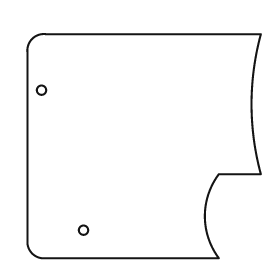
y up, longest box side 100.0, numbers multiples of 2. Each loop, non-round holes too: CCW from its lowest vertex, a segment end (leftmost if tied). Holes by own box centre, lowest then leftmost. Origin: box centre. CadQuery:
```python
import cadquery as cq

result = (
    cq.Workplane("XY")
    .moveTo(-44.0, -48.0)
    .lineTo(32.0, -48.0)
    .threePointArc((26.0, -30.0), (32.0, -12.0))
    .lineTo(50.0, -12.0)
    .threePointArc((46.0, 18.0), (50.0, 48.0))
    .lineTo(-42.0, 48.0)
    .threePointArc((-48.0, 46.0), (-50.0, 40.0))
    .lineTo(-50.0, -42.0)
    .threePointArc((-48.0, -46.0), (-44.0, -48.0))
    .close()
    .moveTo(-26.0, -36.0)
    .circle(2.0)
    .moveTo(-44.0, 24.0)
    .circle(2.0)
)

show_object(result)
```